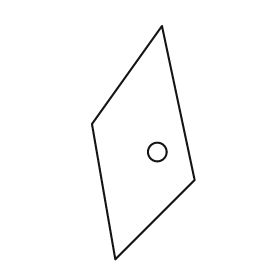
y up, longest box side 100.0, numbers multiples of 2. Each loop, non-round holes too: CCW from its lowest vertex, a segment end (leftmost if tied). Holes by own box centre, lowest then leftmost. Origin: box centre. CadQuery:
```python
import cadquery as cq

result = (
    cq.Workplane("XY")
    .moveTo(-12.0, -50.0)
    .lineTo(22.0, -16.0)
    .lineTo(8.0, 50.0)
    .lineTo(-22.0, 8.0)
    .close()
    .moveTo(6.0, -4.0)
    .circle(4.0)
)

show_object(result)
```